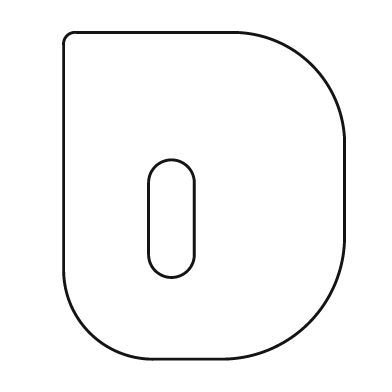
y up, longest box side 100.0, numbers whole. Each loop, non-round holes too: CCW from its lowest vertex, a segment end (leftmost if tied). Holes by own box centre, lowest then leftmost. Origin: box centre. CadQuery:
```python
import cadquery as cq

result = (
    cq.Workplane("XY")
    .moveTo(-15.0, -50.0)
    .lineTo(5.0, -50.0)
    .threePointArc((32.0, -39.0), (43.0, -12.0))
    .lineTo(43.0, 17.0)
    .threePointArc((33.0, 40.0), (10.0, 50.0))
    .lineTo(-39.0, 50.0)
    .threePointArc((-42.0, 49.0), (-43.0, 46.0))
    .lineTo(-43.0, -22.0)
    .threePointArc((-35.0, -42.0), (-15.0, -50.0))
    .close()
    .moveTo(-17.0, -18.0)
    .threePointArc((-10.0, -25.0), (-3.0, -18.0))
    .lineTo(-3.0, 4.0)
    .threePointArc((-10.0, 11.0), (-17.0, 4.0))
    .close()
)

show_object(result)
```